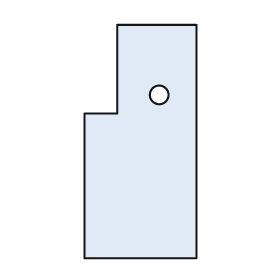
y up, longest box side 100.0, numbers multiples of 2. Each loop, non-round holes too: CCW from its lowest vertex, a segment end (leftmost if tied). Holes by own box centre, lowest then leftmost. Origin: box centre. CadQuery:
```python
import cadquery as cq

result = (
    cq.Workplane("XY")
    .moveTo(-24.0, -50.0)
    .lineTo(24.0, -50.0)
    .lineTo(24.0, 50.0)
    .lineTo(-10.0, 50.0)
    .lineTo(-10.0, 12.0)
    .lineTo(-24.0, 12.0)
    .close()
    .moveTo(8.0, 20.0)
    .circle(4.0)
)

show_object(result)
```